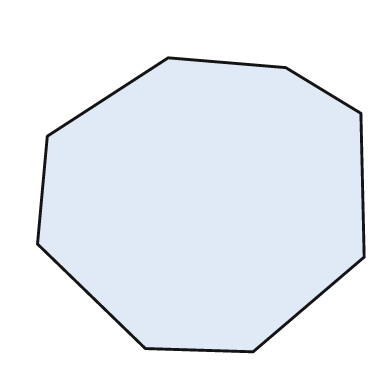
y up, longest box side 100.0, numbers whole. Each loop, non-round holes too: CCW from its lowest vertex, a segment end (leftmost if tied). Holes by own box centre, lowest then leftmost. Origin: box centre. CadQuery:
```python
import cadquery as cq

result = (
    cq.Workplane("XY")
    .moveTo(16.0, -45.0)
    .lineTo(50.0, -16.0)
    .lineTo(49.0, 28.0)
    .lineTo(26.0, 42.0)
    .lineTo(-10.0, 45.0)
    .lineTo(-47.0, 21.0)
    .lineTo(-50.0, -12.0)
    .lineTo(-17.0, -44.0)
    .close()
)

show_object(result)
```